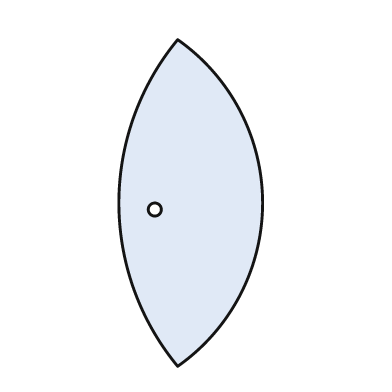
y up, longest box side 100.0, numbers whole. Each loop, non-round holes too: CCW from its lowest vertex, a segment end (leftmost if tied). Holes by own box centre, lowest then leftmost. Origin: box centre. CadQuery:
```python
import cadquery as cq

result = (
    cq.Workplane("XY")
    .moveTo(-4.0, -50.0)
    .threePointArc((22.0, 0.0), (-4.0, 50.0))
    .threePointArc((-22.0, 0.0), (-4.0, -50.0))
    .close()
    .moveTo(-11.0, -2.0)
    .circle(2.0)
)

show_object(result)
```